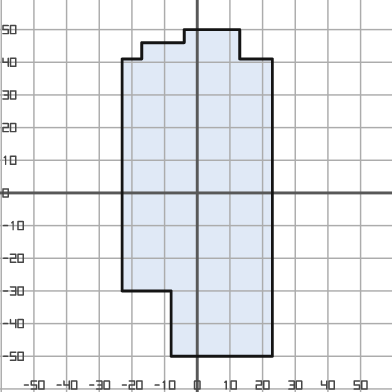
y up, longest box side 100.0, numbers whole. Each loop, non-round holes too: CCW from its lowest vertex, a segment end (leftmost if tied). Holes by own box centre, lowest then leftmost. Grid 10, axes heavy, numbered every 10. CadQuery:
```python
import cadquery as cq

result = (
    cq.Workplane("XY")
    .moveTo(-8.0, -50.0)
    .lineTo(23.0, -50.0)
    .lineTo(23.0, 41.0)
    .lineTo(13.0, 41.0)
    .lineTo(13.0, 50.0)
    .lineTo(-4.0, 50.0)
    .lineTo(-4.0, 46.0)
    .lineTo(-17.0, 46.0)
    .lineTo(-17.0, 41.0)
    .lineTo(-23.0, 41.0)
    .lineTo(-23.0, -30.0)
    .lineTo(-8.0, -30.0)
    .close()
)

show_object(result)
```